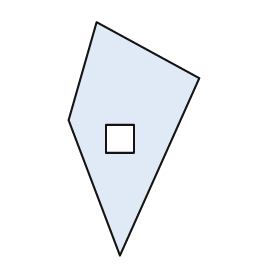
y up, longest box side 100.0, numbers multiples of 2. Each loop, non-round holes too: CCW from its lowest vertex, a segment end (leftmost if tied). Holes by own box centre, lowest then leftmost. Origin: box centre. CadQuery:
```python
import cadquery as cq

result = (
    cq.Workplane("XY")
    .moveTo(-6.0, -50.0)
    .lineTo(28.0, 26.0)
    .lineTo(-16.0, 50.0)
    .lineTo(-28.0, 8.0)
    .close()
    .moveTo(-12.0, -6.0)
    .lineTo(0.0, -6.0)
    .lineTo(0.0, 6.0)
    .lineTo(-12.0, 6.0)
    .close()
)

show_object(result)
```